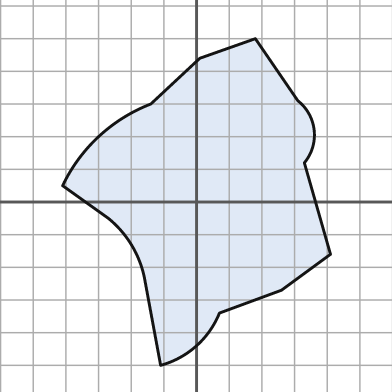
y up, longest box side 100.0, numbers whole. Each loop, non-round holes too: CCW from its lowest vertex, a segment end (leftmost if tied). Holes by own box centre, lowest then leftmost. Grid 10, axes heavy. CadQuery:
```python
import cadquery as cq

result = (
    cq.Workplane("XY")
    .moveTo(-11.0, -50.0)
    .threePointArc((0.0, -44.0), (7.0, -34.0))
    .lineTo(26.0, -27.0)
    .lineTo(41.0, -16.0)
    .lineTo(33.0, 12.0)
    .threePointArc((36.0, 22.0), (31.0, 31.0))
    .lineTo(18.0, 50.0)
    .lineTo(1.0, 44.0)
    .lineTo(-14.0, 30.0)
    .threePointArc((-30.0, 20.0), (-41.0, 5.0))
    .lineTo(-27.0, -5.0)
    .threePointArc((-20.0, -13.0), (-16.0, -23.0))
    .close()
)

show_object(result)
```